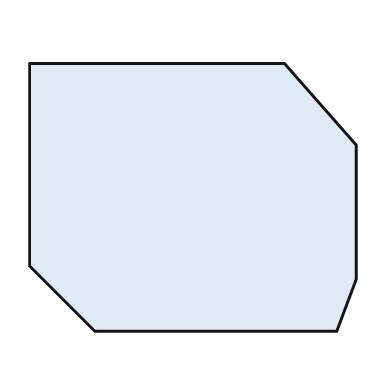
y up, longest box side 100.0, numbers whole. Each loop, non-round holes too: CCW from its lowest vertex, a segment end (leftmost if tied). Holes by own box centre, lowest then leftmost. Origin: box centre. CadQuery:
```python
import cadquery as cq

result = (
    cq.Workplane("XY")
    .moveTo(-30.0, -41.0)
    .lineTo(44.0, -41.0)
    .lineTo(50.0, -25.0)
    .lineTo(50.0, 16.0)
    .lineTo(28.0, 41.0)
    .lineTo(-50.0, 41.0)
    .lineTo(-50.0, -21.0)
    .close()
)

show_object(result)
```